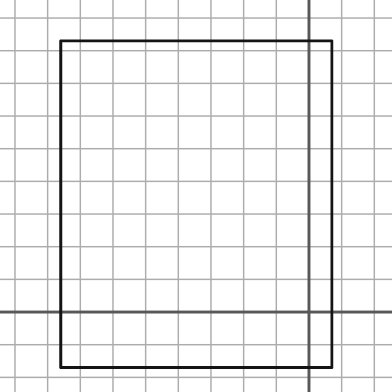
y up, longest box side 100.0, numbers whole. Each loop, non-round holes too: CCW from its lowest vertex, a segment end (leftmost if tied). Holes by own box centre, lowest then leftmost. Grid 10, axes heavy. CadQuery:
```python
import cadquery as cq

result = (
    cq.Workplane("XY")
    .moveTo(-76.0, -17.0)
    .lineTo(7.0, -17.0)
    .lineTo(7.0, 83.0)
    .lineTo(-76.0, 83.0)
    .close()
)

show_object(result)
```